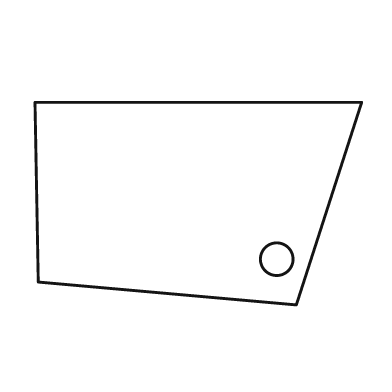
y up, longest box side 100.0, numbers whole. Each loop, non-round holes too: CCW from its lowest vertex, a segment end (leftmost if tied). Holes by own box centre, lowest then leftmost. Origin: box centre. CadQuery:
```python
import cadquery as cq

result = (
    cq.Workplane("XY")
    .moveTo(30.0, -31.0)
    .lineTo(50.0, 31.0)
    .lineTo(-50.0, 31.0)
    .lineTo(-49.0, -24.0)
    .close()
    .moveTo(24.0, -17.0)
    .circle(5.0)
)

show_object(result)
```